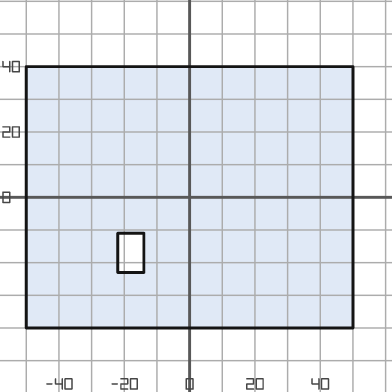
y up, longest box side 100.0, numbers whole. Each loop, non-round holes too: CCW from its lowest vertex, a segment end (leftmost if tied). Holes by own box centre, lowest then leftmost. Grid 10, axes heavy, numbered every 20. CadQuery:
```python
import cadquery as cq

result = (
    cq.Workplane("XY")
    .moveTo(-50.0, -40.0)
    .lineTo(50.0, -40.0)
    .lineTo(50.0, 40.0)
    .lineTo(-50.0, 40.0)
    .close()
    .moveTo(-22.0, -23.0)
    .lineTo(-14.0, -23.0)
    .lineTo(-14.0, -11.0)
    .lineTo(-22.0, -11.0)
    .close()
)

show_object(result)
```